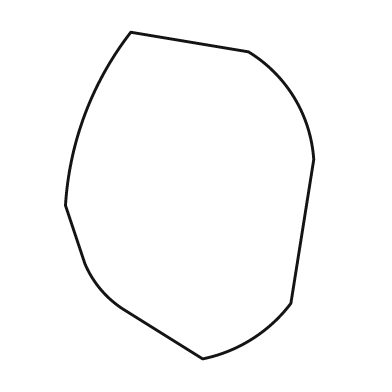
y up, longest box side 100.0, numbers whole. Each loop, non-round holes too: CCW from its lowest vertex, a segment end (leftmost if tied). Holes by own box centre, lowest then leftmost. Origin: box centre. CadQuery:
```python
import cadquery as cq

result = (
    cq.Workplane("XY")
    .moveTo(4.0, -50.0)
    .threePointArc((19.0, -44.0), (31.0, -33.0))
    .lineTo(38.0, 11.0)
    .threePointArc((32.0, 30.0), (18.0, 44.0))
    .lineTo(-18.0, 50.0)
    .threePointArc((-32.0, 25.0), (-38.0, -3.0))
    .lineTo(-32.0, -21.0)
    .threePointArc((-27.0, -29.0), (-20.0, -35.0))
    .close()
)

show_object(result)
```